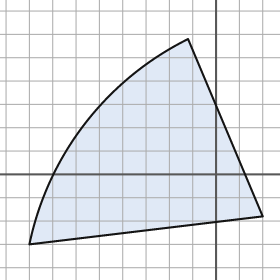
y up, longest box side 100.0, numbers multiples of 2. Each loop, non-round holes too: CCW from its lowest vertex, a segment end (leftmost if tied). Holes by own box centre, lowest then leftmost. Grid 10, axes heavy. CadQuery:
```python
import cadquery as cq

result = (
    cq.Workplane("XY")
    .moveTo(-80.0, -30.0)
    .lineTo(20.0, -18.0)
    .lineTo(-12.0, 58.0)
    .threePointArc((-56.0, 22.0), (-80.0, -30.0))
    .close()
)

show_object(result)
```